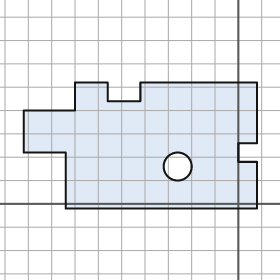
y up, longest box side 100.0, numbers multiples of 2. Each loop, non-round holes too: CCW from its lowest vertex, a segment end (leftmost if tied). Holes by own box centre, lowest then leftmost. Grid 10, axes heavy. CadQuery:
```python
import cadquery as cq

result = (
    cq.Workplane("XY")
    .moveTo(-74.0, -2.0)
    .lineTo(8.0, -2.0)
    .lineTo(8.0, 18.0)
    .lineTo(0.0, 18.0)
    .lineTo(0.0, 26.0)
    .lineTo(8.0, 26.0)
    .lineTo(8.0, 52.0)
    .lineTo(-42.0, 52.0)
    .lineTo(-42.0, 44.0)
    .lineTo(-56.0, 44.0)
    .lineTo(-56.0, 52.0)
    .lineTo(-70.0, 52.0)
    .lineTo(-70.0, 40.0)
    .lineTo(-92.0, 40.0)
    .lineTo(-92.0, 22.0)
    .lineTo(-74.0, 22.0)
    .close()
    .moveTo(-26.0, 16.0)
    .circle(6.0)
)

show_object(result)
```